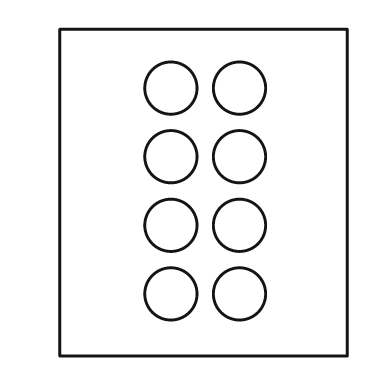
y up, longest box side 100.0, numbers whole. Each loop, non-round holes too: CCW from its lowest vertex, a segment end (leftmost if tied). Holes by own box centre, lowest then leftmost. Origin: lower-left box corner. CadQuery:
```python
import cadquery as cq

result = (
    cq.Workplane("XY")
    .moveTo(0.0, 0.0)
    .lineTo(88.0, 0.0)
    .lineTo(88.0, 100.0)
    .lineTo(0.0, 100.0)
    .close()
    .moveTo(34.0, 19.0)
    .circle(8.0)
    .moveTo(55.0, 19.0)
    .circle(8.0)
    .moveTo(34.0, 40.0)
    .circle(8.0)
    .moveTo(55.0, 40.0)
    .circle(8.0)
    .moveTo(34.0, 61.0)
    .circle(8.0)
    .moveTo(55.0, 61.0)
    .circle(8.0)
    .moveTo(34.0, 82.0)
    .circle(8.0)
    .moveTo(55.0, 82.0)
    .circle(8.0)
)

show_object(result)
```